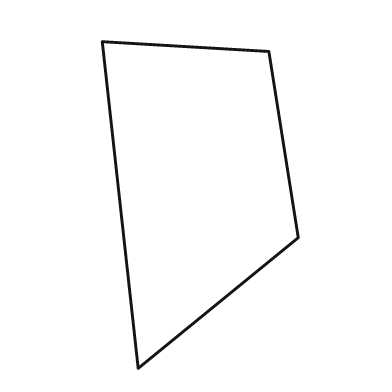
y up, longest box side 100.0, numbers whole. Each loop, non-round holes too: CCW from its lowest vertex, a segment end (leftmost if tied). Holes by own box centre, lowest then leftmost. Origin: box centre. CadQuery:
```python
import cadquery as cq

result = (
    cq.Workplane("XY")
    .moveTo(-19.0, -50.0)
    .lineTo(30.0, -10.0)
    .lineTo(21.0, 47.0)
    .lineTo(-30.0, 50.0)
    .close()
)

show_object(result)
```